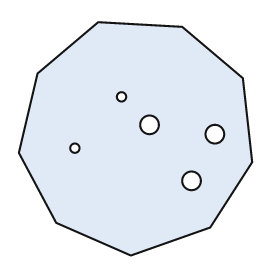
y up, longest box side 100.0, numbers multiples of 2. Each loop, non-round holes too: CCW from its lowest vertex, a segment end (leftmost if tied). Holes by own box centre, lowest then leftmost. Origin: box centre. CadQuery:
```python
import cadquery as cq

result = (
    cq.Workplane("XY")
    .moveTo(-2.0, -50.0)
    .lineTo(32.0, -38.0)
    .lineTo(50.0, -10.0)
    .lineTo(46.0, 26.0)
    .lineTo(20.0, 48.0)
    .lineTo(-16.0, 50.0)
    .lineTo(-42.0, 28.0)
    .lineTo(-50.0, -6.0)
    .lineTo(-34.0, -36.0)
    .close()
    .moveTo(24.0, -18.0)
    .circle(4.0)
    .moveTo(-26.0, -4.0)
    .circle(2.0)
    .moveTo(34.0, 2.0)
    .circle(4.0)
    .moveTo(6.0, 6.0)
    .circle(4.0)
    .moveTo(-6.0, 18.0)
    .circle(2.0)
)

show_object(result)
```